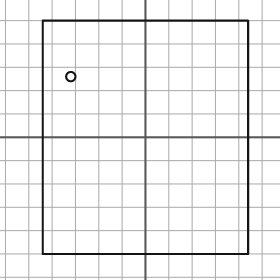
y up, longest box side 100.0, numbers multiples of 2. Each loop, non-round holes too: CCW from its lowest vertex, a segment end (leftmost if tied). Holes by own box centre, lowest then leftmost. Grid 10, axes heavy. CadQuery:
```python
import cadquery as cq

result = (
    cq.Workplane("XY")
    .moveTo(-44.0, -50.0)
    .lineTo(44.0, -50.0)
    .lineTo(44.0, 50.0)
    .lineTo(-44.0, 50.0)
    .close()
    .moveTo(-32.0, 26.0)
    .circle(2.0)
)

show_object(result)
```